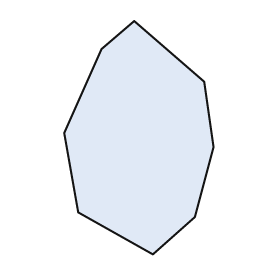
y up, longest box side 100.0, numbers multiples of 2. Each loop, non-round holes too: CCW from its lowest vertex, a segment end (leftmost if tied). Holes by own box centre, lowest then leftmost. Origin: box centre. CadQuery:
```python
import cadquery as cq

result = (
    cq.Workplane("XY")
    .moveTo(6.0, -50.0)
    .lineTo(24.0, -34.0)
    .lineTo(32.0, -4.0)
    .lineTo(28.0, 24.0)
    .lineTo(-2.0, 50.0)
    .lineTo(-16.0, 38.0)
    .lineTo(-32.0, 2.0)
    .lineTo(-26.0, -32.0)
    .close()
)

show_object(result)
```